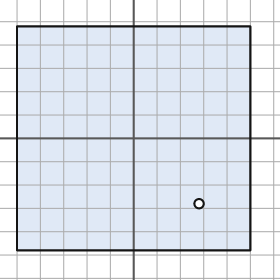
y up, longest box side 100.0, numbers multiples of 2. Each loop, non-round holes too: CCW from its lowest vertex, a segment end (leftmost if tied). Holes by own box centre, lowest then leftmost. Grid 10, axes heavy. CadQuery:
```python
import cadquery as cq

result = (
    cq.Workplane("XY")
    .moveTo(-50.0, -48.0)
    .lineTo(50.0, -48.0)
    .lineTo(50.0, 48.0)
    .lineTo(-50.0, 48.0)
    .close()
    .moveTo(28.0, -28.0)
    .circle(2.0)
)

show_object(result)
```